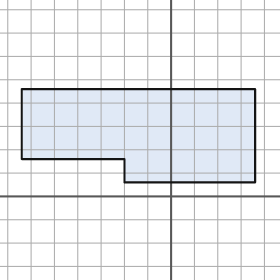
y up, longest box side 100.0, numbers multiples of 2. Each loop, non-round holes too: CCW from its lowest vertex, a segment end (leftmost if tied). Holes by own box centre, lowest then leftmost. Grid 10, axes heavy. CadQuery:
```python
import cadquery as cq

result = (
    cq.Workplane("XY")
    .moveTo(-20.0, 6.0)
    .lineTo(36.0, 6.0)
    .lineTo(36.0, 46.0)
    .lineTo(-64.0, 46.0)
    .lineTo(-64.0, 16.0)
    .lineTo(-20.0, 16.0)
    .close()
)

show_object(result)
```